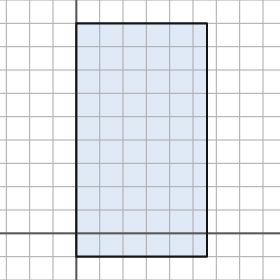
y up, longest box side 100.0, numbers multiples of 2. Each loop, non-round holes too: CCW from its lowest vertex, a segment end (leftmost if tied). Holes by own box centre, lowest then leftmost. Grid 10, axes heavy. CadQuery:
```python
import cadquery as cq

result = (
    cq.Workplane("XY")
    .moveTo(0.0, -10.0)
    .lineTo(56.0, -10.0)
    .lineTo(56.0, 90.0)
    .lineTo(0.0, 90.0)
    .close()
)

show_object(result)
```